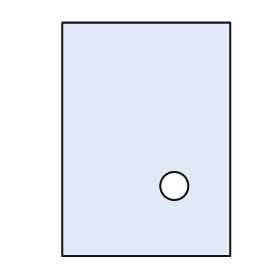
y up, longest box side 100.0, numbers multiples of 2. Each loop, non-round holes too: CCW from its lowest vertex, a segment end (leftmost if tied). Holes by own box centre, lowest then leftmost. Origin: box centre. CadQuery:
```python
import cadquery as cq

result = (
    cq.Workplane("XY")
    .moveTo(-36.0, -50.0)
    .lineTo(36.0, -50.0)
    .lineTo(36.0, 50.0)
    .lineTo(-36.0, 50.0)
    .close()
    .moveTo(12.0, -20.0)
    .circle(6.0)
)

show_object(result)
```